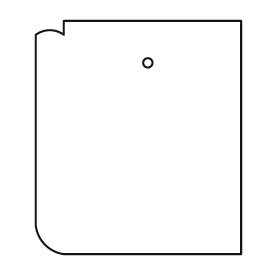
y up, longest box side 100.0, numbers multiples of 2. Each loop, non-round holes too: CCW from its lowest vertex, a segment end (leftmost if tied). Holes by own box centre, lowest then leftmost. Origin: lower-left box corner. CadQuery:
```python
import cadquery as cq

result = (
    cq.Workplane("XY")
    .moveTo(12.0, 0.0)
    .lineTo(88.0, 0.0)
    .lineTo(88.0, 100.0)
    .lineTo(12.0, 100.0)
    .lineTo(12.0, 94.0)
    .threePointArc((6.0, 96.0), (0.0, 94.0))
    .lineTo(0.0, 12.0)
    .threePointArc((4.0, 4.0), (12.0, 0.0))
    .close()
    .moveTo(48.0, 82.0)
    .circle(2.0)
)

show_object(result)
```